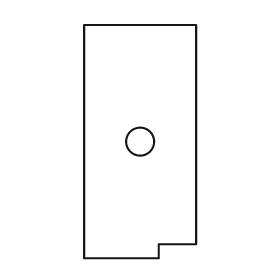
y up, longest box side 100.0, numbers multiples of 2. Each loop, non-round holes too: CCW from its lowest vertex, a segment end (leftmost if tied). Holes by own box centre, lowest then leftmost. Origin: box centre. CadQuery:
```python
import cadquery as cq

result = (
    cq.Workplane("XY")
    .moveTo(-24.0, -50.0)
    .lineTo(8.0, -50.0)
    .lineTo(8.0, -44.0)
    .lineTo(24.0, -44.0)
    .lineTo(24.0, 50.0)
    .lineTo(-24.0, 50.0)
    .close()
    .moveTo(0.0, 0.0)
    .circle(6.0)
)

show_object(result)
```